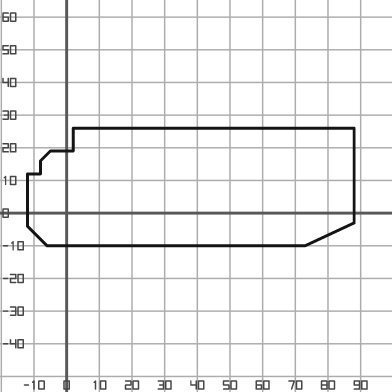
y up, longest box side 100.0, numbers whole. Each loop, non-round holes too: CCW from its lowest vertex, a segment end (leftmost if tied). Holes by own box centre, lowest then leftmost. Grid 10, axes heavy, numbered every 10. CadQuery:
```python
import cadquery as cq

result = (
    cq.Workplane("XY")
    .moveTo(-6.0, -10.0)
    .lineTo(73.0, -10.0)
    .lineTo(88.0, -3.0)
    .lineTo(88.0, 26.0)
    .lineTo(2.0, 26.0)
    .lineTo(2.0, 19.0)
    .lineTo(-5.0, 19.0)
    .lineTo(-8.0, 16.0)
    .lineTo(-8.0, 12.0)
    .lineTo(-12.0, 12.0)
    .lineTo(-12.0, -4.0)
    .close()
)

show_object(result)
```